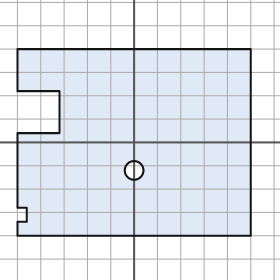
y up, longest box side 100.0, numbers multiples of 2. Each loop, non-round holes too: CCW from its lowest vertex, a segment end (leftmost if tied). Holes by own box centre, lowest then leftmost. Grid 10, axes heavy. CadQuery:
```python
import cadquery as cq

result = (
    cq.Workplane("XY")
    .moveTo(-50.0, -40.0)
    .lineTo(50.0, -40.0)
    .lineTo(50.0, 40.0)
    .lineTo(-50.0, 40.0)
    .lineTo(-50.0, 22.0)
    .lineTo(-32.0, 22.0)
    .lineTo(-32.0, 4.0)
    .lineTo(-50.0, 4.0)
    .lineTo(-50.0, -28.0)
    .lineTo(-46.0, -28.0)
    .lineTo(-46.0, -34.0)
    .lineTo(-50.0, -34.0)
    .close()
    .moveTo(0.0, -12.0)
    .circle(4.0)
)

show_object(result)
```